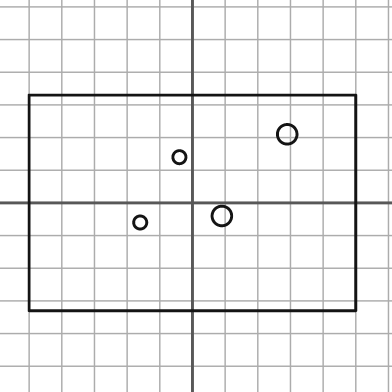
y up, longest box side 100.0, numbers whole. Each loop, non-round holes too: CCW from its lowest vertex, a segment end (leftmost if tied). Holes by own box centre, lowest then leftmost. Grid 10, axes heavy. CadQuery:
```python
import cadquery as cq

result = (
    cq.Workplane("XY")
    .moveTo(-50.0, -33.0)
    .lineTo(50.0, -33.0)
    .lineTo(50.0, 33.0)
    .lineTo(-50.0, 33.0)
    .close()
    .moveTo(-16.0, -6.0)
    .circle(2.0)
    .moveTo(9.0, -4.0)
    .circle(3.0)
    .moveTo(-4.0, 14.0)
    .circle(2.0)
    .moveTo(29.0, 21.0)
    .circle(3.0)
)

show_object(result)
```